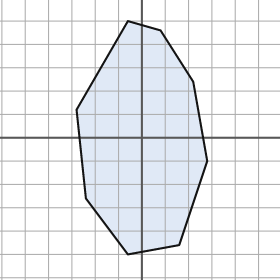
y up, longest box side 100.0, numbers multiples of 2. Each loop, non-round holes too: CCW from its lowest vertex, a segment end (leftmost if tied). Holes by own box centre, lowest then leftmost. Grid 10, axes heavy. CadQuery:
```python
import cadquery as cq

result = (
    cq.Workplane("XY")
    .moveTo(-6.0, -50.0)
    .lineTo(16.0, -46.0)
    .lineTo(28.0, -10.0)
    .lineTo(22.0, 24.0)
    .lineTo(8.0, 46.0)
    .lineTo(-6.0, 50.0)
    .lineTo(-28.0, 12.0)
    .lineTo(-24.0, -26.0)
    .close()
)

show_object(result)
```